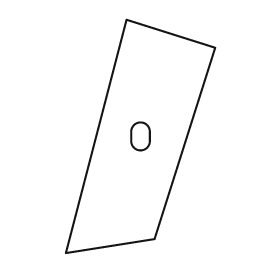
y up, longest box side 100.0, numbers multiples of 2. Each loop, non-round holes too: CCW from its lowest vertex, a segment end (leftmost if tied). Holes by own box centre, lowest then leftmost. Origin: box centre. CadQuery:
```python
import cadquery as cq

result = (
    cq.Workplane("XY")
    .moveTo(-32.0, -50.0)
    .lineTo(6.0, -44.0)
    .lineTo(32.0, 38.0)
    .lineTo(-6.0, 50.0)
    .close()
    .moveTo(-4.0, -2.0)
    .threePointArc((0.0, -6.0), (4.0, -2.0))
    .lineTo(4.0, 2.0)
    .threePointArc((0.0, 6.0), (-4.0, 2.0))
    .close()
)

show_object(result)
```